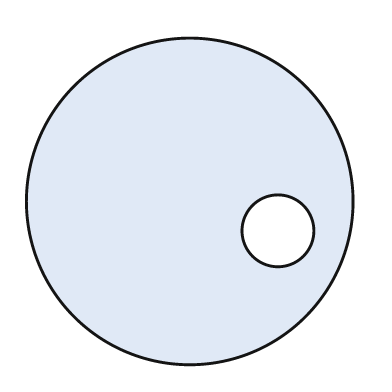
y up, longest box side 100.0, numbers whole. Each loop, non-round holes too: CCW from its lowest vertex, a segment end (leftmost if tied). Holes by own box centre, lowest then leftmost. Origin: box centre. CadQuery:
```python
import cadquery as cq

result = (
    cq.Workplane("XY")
    .moveTo(0.0, 0.0)
    .circle(50.0)
    .moveTo(27.0, -9.0)
    .circle(11.0)
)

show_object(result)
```